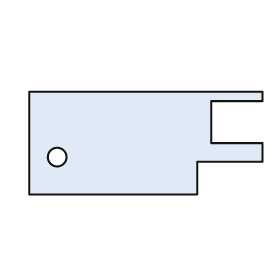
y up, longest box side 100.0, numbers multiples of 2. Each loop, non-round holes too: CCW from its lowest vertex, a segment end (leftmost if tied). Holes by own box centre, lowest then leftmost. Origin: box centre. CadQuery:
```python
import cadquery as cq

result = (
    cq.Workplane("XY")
    .moveTo(-50.0, -22.0)
    .lineTo(22.0, -22.0)
    .lineTo(22.0, -8.0)
    .lineTo(50.0, -8.0)
    .lineTo(50.0, 0.0)
    .lineTo(28.0, 0.0)
    .lineTo(28.0, 18.0)
    .lineTo(50.0, 18.0)
    .lineTo(50.0, 22.0)
    .lineTo(-50.0, 22.0)
    .close()
    .moveTo(-38.0, -6.0)
    .circle(4.0)
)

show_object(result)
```